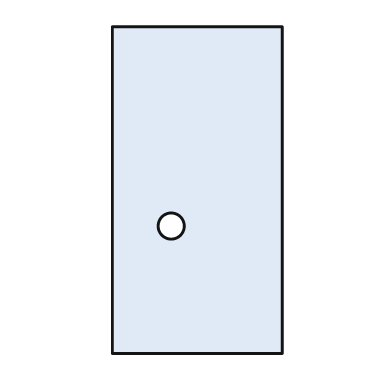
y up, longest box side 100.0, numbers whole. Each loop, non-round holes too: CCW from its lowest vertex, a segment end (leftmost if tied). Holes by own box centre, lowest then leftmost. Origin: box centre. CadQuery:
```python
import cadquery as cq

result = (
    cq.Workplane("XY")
    .moveTo(-26.0, -50.0)
    .lineTo(26.0, -50.0)
    .lineTo(26.0, 50.0)
    .lineTo(-26.0, 50.0)
    .close()
    .moveTo(-8.0, -11.0)
    .circle(4.0)
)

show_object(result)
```